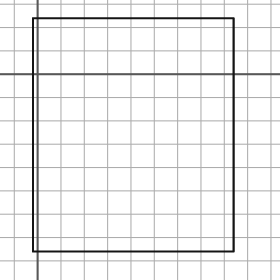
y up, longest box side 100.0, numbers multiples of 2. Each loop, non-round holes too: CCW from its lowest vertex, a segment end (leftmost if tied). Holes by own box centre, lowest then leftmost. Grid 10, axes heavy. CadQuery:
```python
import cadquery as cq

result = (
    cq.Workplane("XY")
    .moveTo(-2.0, -76.0)
    .lineTo(84.0, -76.0)
    .lineTo(84.0, 24.0)
    .lineTo(-2.0, 24.0)
    .close()
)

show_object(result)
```